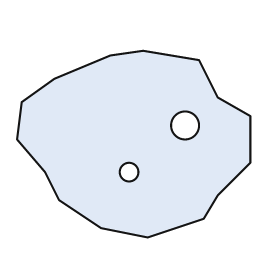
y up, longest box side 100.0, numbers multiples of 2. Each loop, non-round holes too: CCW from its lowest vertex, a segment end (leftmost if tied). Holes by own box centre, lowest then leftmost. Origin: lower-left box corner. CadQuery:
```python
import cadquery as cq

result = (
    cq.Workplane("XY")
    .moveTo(56.0, 0.0)
    .lineTo(80.0, 8.0)
    .lineTo(86.0, 18.0)
    .lineTo(100.0, 32.0)
    .lineTo(100.0, 52.0)
    .lineTo(86.0, 60.0)
    .lineTo(78.0, 76.0)
    .lineTo(54.0, 80.0)
    .lineTo(40.0, 78.0)
    .lineTo(16.0, 68.0)
    .lineTo(2.0, 58.0)
    .lineTo(0.0, 42.0)
    .lineTo(12.0, 28.0)
    .lineTo(18.0, 16.0)
    .lineTo(36.0, 4.0)
    .close()
    .moveTo(48.0, 28.0)
    .circle(4.0)
    .moveTo(72.0, 48.0)
    .circle(6.0)
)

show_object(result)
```